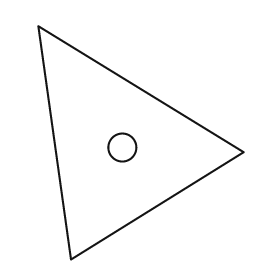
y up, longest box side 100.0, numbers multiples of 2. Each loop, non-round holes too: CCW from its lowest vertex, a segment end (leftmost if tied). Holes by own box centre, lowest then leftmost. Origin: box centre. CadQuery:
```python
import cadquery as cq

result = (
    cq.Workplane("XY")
    .moveTo(-30.0, -50.0)
    .lineTo(44.0, -4.0)
    .lineTo(-44.0, 50.0)
    .close()
    .moveTo(-8.0, -2.0)
    .circle(6.0)
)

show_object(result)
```